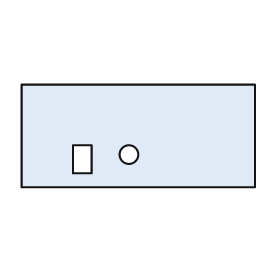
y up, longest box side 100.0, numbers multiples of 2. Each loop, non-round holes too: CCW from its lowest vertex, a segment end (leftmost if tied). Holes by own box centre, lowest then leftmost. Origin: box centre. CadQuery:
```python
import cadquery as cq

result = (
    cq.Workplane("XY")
    .moveTo(-50.0, -22.0)
    .lineTo(50.0, -22.0)
    .lineTo(50.0, 22.0)
    .lineTo(-50.0, 22.0)
    .close()
    .moveTo(-28.0, -16.0)
    .lineTo(-20.0, -16.0)
    .lineTo(-20.0, -4.0)
    .lineTo(-28.0, -4.0)
    .close()
    .moveTo(-4.0, -8.0)
    .circle(4.0)
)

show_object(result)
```